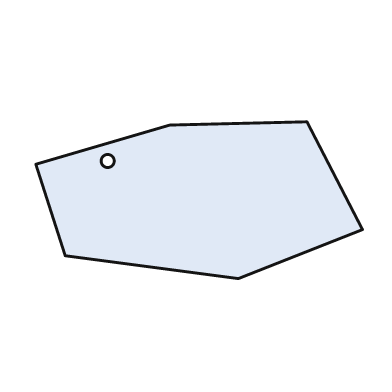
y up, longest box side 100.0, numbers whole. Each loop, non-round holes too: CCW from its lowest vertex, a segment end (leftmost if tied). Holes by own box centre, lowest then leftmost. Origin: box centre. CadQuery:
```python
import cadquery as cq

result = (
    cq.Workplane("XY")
    .moveTo(12.0, -24.0)
    .lineTo(50.0, -9.0)
    .lineTo(33.0, 24.0)
    .lineTo(-9.0, 23.0)
    .lineTo(-50.0, 11.0)
    .lineTo(-41.0, -17.0)
    .close()
    .moveTo(-28.0, 12.0)
    .circle(2.0)
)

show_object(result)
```